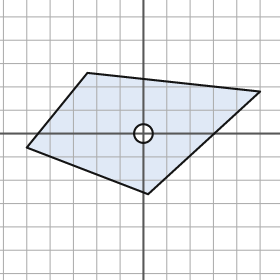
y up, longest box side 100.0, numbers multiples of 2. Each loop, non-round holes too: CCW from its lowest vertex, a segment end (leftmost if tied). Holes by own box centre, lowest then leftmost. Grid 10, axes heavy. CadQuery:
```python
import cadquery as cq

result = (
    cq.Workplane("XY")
    .moveTo(2.0, -26.0)
    .lineTo(50.0, 18.0)
    .lineTo(-24.0, 26.0)
    .lineTo(-50.0, -6.0)
    .close()
    .moveTo(0.0, 0.0)
    .circle(4.0)
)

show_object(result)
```